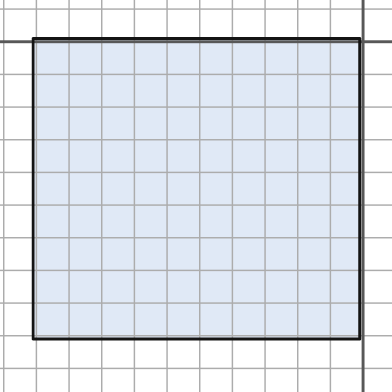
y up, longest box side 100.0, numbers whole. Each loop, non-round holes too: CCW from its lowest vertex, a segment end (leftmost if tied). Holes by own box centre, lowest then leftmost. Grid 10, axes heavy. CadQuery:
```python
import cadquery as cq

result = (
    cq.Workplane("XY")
    .moveTo(-101.0, -91.0)
    .lineTo(-1.0, -91.0)
    .lineTo(-1.0, 1.0)
    .lineTo(-101.0, 1.0)
    .close()
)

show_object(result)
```